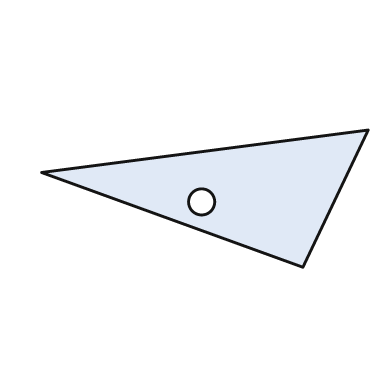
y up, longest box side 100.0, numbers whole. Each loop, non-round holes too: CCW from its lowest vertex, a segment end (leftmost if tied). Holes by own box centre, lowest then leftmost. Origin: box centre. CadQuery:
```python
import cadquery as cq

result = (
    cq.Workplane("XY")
    .moveTo(30.0, -21.0)
    .lineTo(50.0, 21.0)
    .lineTo(-50.0, 8.0)
    .close()
    .moveTo(-1.0, -1.0)
    .circle(4.0)
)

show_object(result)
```